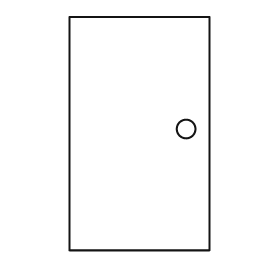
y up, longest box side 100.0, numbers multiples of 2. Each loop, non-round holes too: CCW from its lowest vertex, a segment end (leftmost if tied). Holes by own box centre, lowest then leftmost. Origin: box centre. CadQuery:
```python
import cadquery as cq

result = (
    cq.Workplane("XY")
    .moveTo(-30.0, -50.0)
    .lineTo(30.0, -50.0)
    .lineTo(30.0, 50.0)
    .lineTo(-30.0, 50.0)
    .close()
    .moveTo(20.0, 2.0)
    .circle(4.0)
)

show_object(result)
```